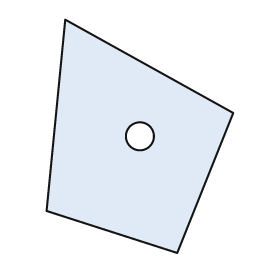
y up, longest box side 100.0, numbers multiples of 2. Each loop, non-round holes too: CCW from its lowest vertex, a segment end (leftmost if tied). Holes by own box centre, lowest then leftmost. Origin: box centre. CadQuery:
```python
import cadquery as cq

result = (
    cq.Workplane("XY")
    .moveTo(16.0, -50.0)
    .lineTo(40.0, 10.0)
    .lineTo(-32.0, 50.0)
    .lineTo(-40.0, -32.0)
    .close()
    .moveTo(0.0, 0.0)
    .circle(6.0)
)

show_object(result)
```